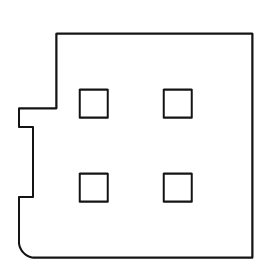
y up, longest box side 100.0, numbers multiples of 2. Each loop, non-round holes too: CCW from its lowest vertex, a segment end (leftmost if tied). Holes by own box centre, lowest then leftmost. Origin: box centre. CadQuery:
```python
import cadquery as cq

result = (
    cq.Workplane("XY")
    .moveTo(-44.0, -48.0)
    .lineTo(50.0, -48.0)
    .lineTo(50.0, 48.0)
    .lineTo(-34.0, 48.0)
    .lineTo(-34.0, 16.0)
    .lineTo(-50.0, 16.0)
    .lineTo(-50.0, 8.0)
    .lineTo(-44.0, 8.0)
    .lineTo(-44.0, -22.0)
    .lineTo(-50.0, -22.0)
    .lineTo(-50.0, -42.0)
    .threePointArc((-48.0, -46.0), (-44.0, -48.0))
    .close()
    .moveTo(-24.0, -24.0)
    .lineTo(-12.0, -24.0)
    .lineTo(-12.0, -12.0)
    .lineTo(-24.0, -12.0)
    .close()
    .moveTo(12.0, -24.0)
    .lineTo(24.0, -24.0)
    .lineTo(24.0, -12.0)
    .lineTo(12.0, -12.0)
    .close()
    .moveTo(-24.0, 12.0)
    .lineTo(-12.0, 12.0)
    .lineTo(-12.0, 24.0)
    .lineTo(-24.0, 24.0)
    .close()
    .moveTo(12.0, 12.0)
    .lineTo(24.0, 12.0)
    .lineTo(24.0, 24.0)
    .lineTo(12.0, 24.0)
    .close()
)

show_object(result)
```